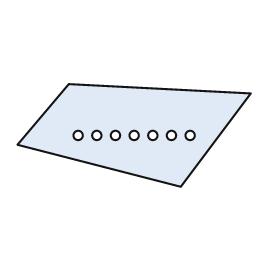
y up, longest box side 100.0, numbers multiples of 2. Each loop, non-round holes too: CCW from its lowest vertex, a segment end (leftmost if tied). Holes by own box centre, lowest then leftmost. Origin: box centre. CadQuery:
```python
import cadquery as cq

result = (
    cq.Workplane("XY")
    .moveTo(20.0, -22.0)
    .lineTo(50.0, 18.0)
    .lineTo(-28.0, 22.0)
    .lineTo(-50.0, -4.0)
    .close()
    .moveTo(-24.0, 0.0)
    .circle(2.0)
    .moveTo(-16.0, 0.0)
    .circle(2.0)
    .moveTo(-8.0, 0.0)
    .circle(2.0)
    .moveTo(0.0, 0.0)
    .circle(2.0)
    .moveTo(8.0, 0.0)
    .circle(2.0)
    .moveTo(16.0, 0.0)
    .circle(2.0)
    .moveTo(24.0, 0.0)
    .circle(2.0)
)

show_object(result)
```